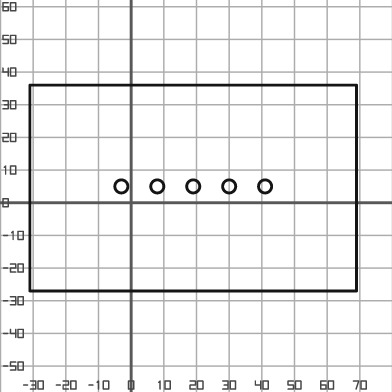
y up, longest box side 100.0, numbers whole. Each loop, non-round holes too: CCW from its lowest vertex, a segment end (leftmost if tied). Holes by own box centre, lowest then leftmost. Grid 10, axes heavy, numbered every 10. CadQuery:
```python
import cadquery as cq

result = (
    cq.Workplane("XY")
    .moveTo(-31.0, -27.0)
    .lineTo(69.0, -27.0)
    .lineTo(69.0, 36.0)
    .lineTo(-31.0, 36.0)
    .close()
    .moveTo(-3.0, 5.0)
    .circle(2.0)
    .moveTo(8.0, 5.0)
    .circle(2.0)
    .moveTo(19.0, 5.0)
    .circle(2.0)
    .moveTo(30.0, 5.0)
    .circle(2.0)
    .moveTo(41.0, 5.0)
    .circle(2.0)
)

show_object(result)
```